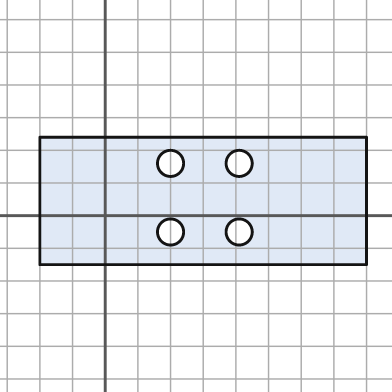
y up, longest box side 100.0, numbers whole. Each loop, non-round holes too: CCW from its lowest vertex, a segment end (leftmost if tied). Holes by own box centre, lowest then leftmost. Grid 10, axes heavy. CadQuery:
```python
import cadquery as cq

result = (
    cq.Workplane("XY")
    .moveTo(-20.0, -15.0)
    .lineTo(80.0, -15.0)
    .lineTo(80.0, 24.0)
    .lineTo(-20.0, 24.0)
    .close()
    .moveTo(20.0, -5.0)
    .circle(4.0)
    .moveTo(41.0, -5.0)
    .circle(4.0)
    .moveTo(20.0, 16.0)
    .circle(4.0)
    .moveTo(41.0, 16.0)
    .circle(4.0)
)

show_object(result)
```